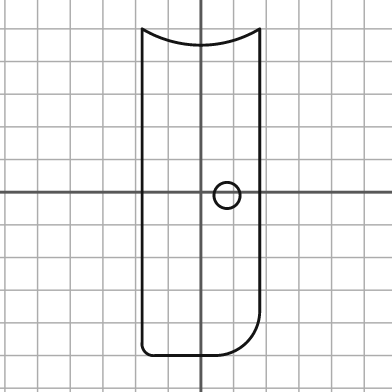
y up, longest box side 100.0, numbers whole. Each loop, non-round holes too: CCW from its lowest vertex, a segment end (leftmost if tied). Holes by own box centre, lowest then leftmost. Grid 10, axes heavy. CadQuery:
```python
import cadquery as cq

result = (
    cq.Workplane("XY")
    .moveTo(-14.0, -50.0)
    .lineTo(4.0, -50.0)
    .threePointArc((14.0, -46.0), (18.0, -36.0))
    .lineTo(18.0, 50.0)
    .threePointArc((0.0, 45.0), (-18.0, 50.0))
    .lineTo(-18.0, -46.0)
    .threePointArc((-17.0, -49.0), (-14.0, -50.0))
    .close()
    .moveTo(8.0, -1.0)
    .circle(4.0)
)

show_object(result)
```